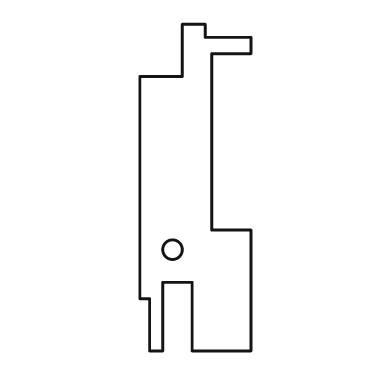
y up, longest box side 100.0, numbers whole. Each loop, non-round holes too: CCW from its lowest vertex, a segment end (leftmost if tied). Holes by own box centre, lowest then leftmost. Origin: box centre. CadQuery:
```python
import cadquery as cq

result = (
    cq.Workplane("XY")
    .moveTo(-14.0, -50.0)
    .lineTo(-10.0, -50.0)
    .lineTo(-10.0, -29.0)
    .lineTo(-1.0, -29.0)
    .lineTo(-1.0, -50.0)
    .lineTo(17.0, -50.0)
    .lineTo(17.0, -13.0)
    .lineTo(5.0, -13.0)
    .lineTo(5.0, 41.0)
    .lineTo(17.0, 41.0)
    .lineTo(17.0, 46.0)
    .lineTo(3.0, 46.0)
    .lineTo(3.0, 50.0)
    .lineTo(-4.0, 50.0)
    .lineTo(-4.0, 34.0)
    .lineTo(-17.0, 34.0)
    .lineTo(-17.0, -34.0)
    .lineTo(-14.0, -34.0)
    .close()
    .moveTo(-7.0, -19.0)
    .circle(3.0)
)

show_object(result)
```